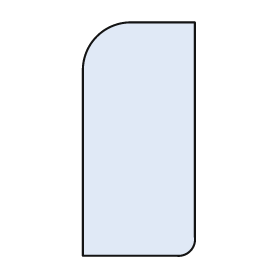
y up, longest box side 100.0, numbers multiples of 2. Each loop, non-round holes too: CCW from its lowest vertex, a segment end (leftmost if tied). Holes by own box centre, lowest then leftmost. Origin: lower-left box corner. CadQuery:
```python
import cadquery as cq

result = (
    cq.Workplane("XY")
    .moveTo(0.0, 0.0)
    .lineTo(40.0, 0.0)
    .threePointArc((46.0, 2.0), (48.0, 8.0))
    .lineTo(48.0, 100.0)
    .lineTo(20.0, 100.0)
    .threePointArc((6.0, 94.0), (0.0, 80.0))
    .close()
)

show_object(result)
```